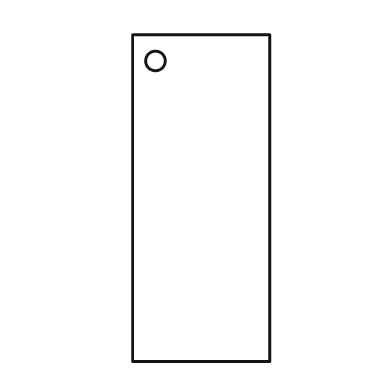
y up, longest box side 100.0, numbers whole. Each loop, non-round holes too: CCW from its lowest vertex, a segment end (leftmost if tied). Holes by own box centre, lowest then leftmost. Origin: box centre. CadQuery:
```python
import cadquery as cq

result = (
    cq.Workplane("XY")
    .moveTo(-21.0, -50.0)
    .lineTo(21.0, -50.0)
    .lineTo(21.0, 50.0)
    .lineTo(-21.0, 50.0)
    .close()
    .moveTo(-14.0, 42.0)
    .circle(3.0)
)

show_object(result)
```